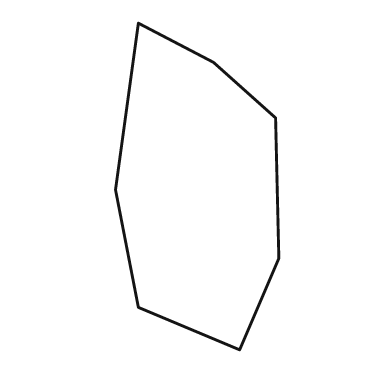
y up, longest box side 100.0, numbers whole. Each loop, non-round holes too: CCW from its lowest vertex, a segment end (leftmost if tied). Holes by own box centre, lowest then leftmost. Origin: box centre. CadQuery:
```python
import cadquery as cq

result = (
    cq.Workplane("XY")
    .moveTo(13.0, -50.0)
    .lineTo(25.0, -22.0)
    .lineTo(24.0, 21.0)
    .lineTo(5.0, 38.0)
    .lineTo(-18.0, 50.0)
    .lineTo(-25.0, -1.0)
    .lineTo(-18.0, -37.0)
    .close()
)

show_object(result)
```